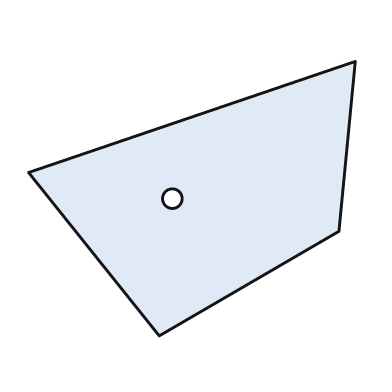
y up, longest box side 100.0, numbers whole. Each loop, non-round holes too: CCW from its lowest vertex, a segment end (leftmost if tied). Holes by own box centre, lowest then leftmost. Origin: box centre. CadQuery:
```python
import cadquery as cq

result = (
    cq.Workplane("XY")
    .moveTo(-10.0, -42.0)
    .lineTo(45.0, -10.0)
    .lineTo(50.0, 42.0)
    .lineTo(-50.0, 8.0)
    .close()
    .moveTo(-6.0, 0.0)
    .circle(3.0)
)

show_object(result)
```